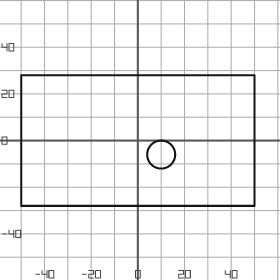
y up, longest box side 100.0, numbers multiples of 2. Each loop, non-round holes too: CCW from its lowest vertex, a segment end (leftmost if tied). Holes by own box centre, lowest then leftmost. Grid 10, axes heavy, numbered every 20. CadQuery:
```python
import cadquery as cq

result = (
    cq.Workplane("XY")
    .moveTo(-50.0, -28.0)
    .lineTo(50.0, -28.0)
    .lineTo(50.0, 28.0)
    .lineTo(-50.0, 28.0)
    .close()
    .moveTo(10.0, -6.0)
    .circle(6.0)
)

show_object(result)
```